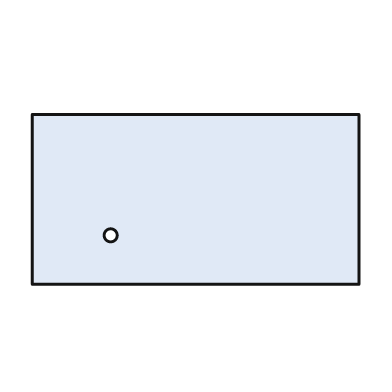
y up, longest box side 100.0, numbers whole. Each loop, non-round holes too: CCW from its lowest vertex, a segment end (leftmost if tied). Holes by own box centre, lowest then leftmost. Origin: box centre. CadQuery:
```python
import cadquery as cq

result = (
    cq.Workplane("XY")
    .moveTo(-50.0, -26.0)
    .lineTo(50.0, -26.0)
    .lineTo(50.0, 26.0)
    .lineTo(-50.0, 26.0)
    .close()
    .moveTo(-26.0, -11.0)
    .circle(2.0)
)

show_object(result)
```